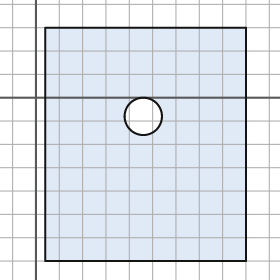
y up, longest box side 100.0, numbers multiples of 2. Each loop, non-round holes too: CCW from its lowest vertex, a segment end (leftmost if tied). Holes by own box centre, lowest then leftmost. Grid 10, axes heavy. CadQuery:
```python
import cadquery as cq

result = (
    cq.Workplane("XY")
    .moveTo(4.0, -70.0)
    .lineTo(90.0, -70.0)
    .lineTo(90.0, 30.0)
    .lineTo(4.0, 30.0)
    .close()
    .moveTo(46.0, -8.0)
    .circle(8.0)
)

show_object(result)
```